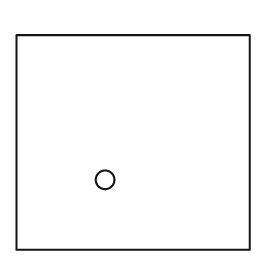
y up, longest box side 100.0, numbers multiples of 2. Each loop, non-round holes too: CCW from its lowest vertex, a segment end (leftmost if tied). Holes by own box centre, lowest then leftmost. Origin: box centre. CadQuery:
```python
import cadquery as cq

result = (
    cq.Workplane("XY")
    .moveTo(-50.0, -46.0)
    .lineTo(50.0, -46.0)
    .lineTo(50.0, 46.0)
    .lineTo(-50.0, 46.0)
    .close()
    .moveTo(-12.0, -16.0)
    .circle(4.0)
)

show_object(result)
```